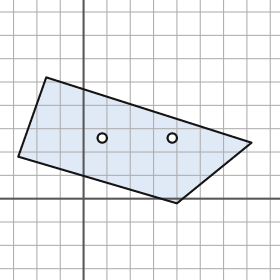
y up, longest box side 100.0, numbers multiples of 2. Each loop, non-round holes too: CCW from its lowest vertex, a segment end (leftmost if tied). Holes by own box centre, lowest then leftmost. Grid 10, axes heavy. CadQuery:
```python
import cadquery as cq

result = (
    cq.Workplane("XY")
    .moveTo(40.0, -2.0)
    .lineTo(72.0, 24.0)
    .lineTo(-16.0, 52.0)
    .lineTo(-28.0, 18.0)
    .close()
    .moveTo(8.0, 26.0)
    .circle(2.0)
    .moveTo(38.0, 26.0)
    .circle(2.0)
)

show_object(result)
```